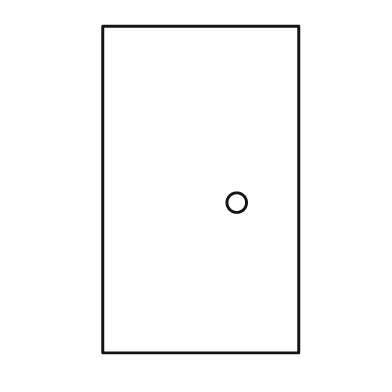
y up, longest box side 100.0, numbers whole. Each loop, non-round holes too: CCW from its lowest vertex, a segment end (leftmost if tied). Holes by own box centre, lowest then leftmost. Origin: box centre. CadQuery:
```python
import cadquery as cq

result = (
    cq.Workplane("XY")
    .moveTo(-30.0, -50.0)
    .lineTo(30.0, -50.0)
    .lineTo(30.0, 50.0)
    .lineTo(-30.0, 50.0)
    .close()
    .moveTo(11.0, -4.0)
    .circle(3.0)
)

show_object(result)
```